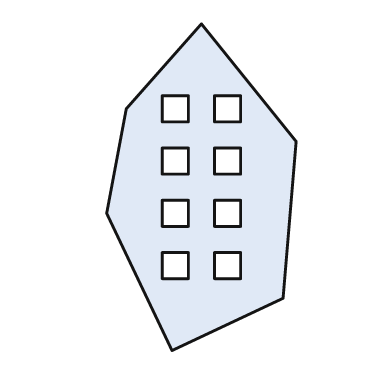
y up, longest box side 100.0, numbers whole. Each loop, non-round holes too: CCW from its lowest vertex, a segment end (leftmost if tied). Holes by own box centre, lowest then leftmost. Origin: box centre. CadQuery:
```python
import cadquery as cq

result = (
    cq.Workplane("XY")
    .moveTo(-9.0, -50.0)
    .lineTo(25.0, -34.0)
    .lineTo(29.0, 14.0)
    .lineTo(0.0, 50.0)
    .lineTo(-23.0, 24.0)
    .lineTo(-29.0, -8.0)
    .close()
    .moveTo(-12.0, -28.0)
    .lineTo(-4.0, -28.0)
    .lineTo(-4.0, -20.0)
    .lineTo(-12.0, -20.0)
    .close()
    .moveTo(4.0, -28.0)
    .lineTo(12.0, -28.0)
    .lineTo(12.0, -20.0)
    .lineTo(4.0, -20.0)
    .close()
    .moveTo(-12.0, -12.0)
    .lineTo(-4.0, -12.0)
    .lineTo(-4.0, -4.0)
    .lineTo(-12.0, -4.0)
    .close()
    .moveTo(4.0, -12.0)
    .lineTo(12.0, -12.0)
    .lineTo(12.0, -4.0)
    .lineTo(4.0, -4.0)
    .close()
    .moveTo(-12.0, 4.0)
    .lineTo(-4.0, 4.0)
    .lineTo(-4.0, 12.0)
    .lineTo(-12.0, 12.0)
    .close()
    .moveTo(4.0, 4.0)
    .lineTo(12.0, 4.0)
    .lineTo(12.0, 12.0)
    .lineTo(4.0, 12.0)
    .close()
    .moveTo(-12.0, 20.0)
    .lineTo(-4.0, 20.0)
    .lineTo(-4.0, 28.0)
    .lineTo(-12.0, 28.0)
    .close()
    .moveTo(4.0, 20.0)
    .lineTo(12.0, 20.0)
    .lineTo(12.0, 28.0)
    .lineTo(4.0, 28.0)
    .close()
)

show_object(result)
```